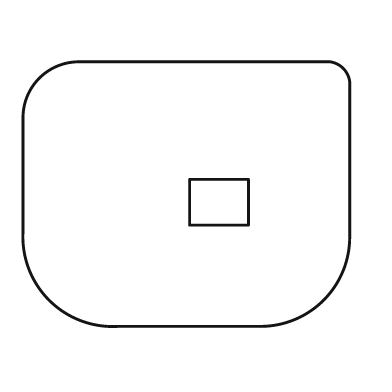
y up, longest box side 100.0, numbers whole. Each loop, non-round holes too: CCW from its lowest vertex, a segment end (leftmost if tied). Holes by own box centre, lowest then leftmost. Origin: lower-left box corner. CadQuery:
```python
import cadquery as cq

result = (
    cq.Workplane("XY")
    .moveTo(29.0, 0.0)
    .lineTo(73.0, 0.0)
    .threePointArc((92.0, 8.0), (100.0, 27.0))
    .lineTo(100.0, 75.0)
    .threePointArc((98.0, 79.0), (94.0, 81.0))
    .lineTo(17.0, 81.0)
    .threePointArc((5.0, 76.0), (0.0, 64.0))
    .lineTo(0.0, 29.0)
    .threePointArc((8.0, 8.0), (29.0, 0.0))
    .close()
    .moveTo(51.0, 31.0)
    .lineTo(69.0, 31.0)
    .lineTo(69.0, 45.0)
    .lineTo(51.0, 45.0)
    .close()
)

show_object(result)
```